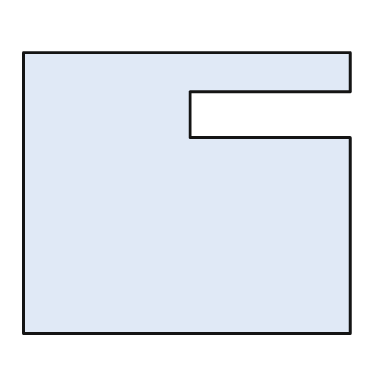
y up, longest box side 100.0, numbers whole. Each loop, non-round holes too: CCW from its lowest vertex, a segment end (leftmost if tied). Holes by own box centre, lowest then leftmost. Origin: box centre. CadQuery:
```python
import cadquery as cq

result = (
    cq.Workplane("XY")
    .moveTo(-50.0, -43.0)
    .lineTo(50.0, -43.0)
    .lineTo(50.0, 17.0)
    .lineTo(1.0, 17.0)
    .lineTo(1.0, 31.0)
    .lineTo(50.0, 31.0)
    .lineTo(50.0, 43.0)
    .lineTo(-50.0, 43.0)
    .close()
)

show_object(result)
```